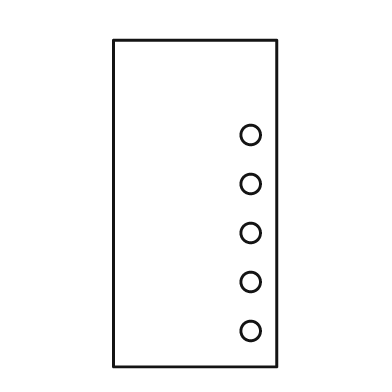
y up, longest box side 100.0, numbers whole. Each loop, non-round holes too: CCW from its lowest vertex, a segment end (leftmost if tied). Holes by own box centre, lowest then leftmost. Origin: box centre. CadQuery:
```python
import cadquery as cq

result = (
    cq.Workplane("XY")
    .moveTo(-25.0, -50.0)
    .lineTo(25.0, -50.0)
    .lineTo(25.0, 50.0)
    .lineTo(-25.0, 50.0)
    .close()
    .moveTo(17.0, -39.0)
    .circle(3.0)
    .moveTo(17.0, -24.0)
    .circle(3.0)
    .moveTo(17.0, -9.0)
    .circle(3.0)
    .moveTo(17.0, 6.0)
    .circle(3.0)
    .moveTo(17.0, 21.0)
    .circle(3.0)
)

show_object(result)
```